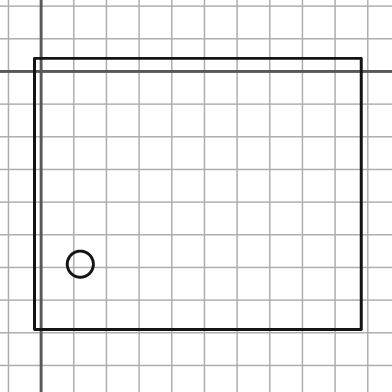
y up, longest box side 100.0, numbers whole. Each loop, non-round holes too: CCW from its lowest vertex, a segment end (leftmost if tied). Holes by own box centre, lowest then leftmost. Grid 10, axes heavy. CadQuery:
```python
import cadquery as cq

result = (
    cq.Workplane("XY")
    .moveTo(-2.0, -79.0)
    .lineTo(98.0, -79.0)
    .lineTo(98.0, 4.0)
    .lineTo(-2.0, 4.0)
    .close()
    .moveTo(12.0, -59.0)
    .circle(4.0)
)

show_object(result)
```